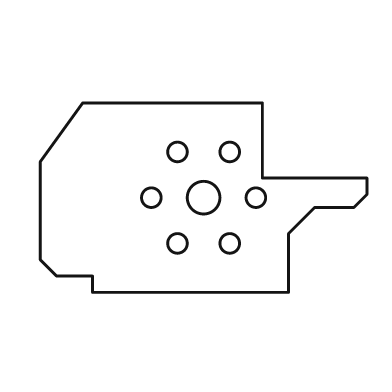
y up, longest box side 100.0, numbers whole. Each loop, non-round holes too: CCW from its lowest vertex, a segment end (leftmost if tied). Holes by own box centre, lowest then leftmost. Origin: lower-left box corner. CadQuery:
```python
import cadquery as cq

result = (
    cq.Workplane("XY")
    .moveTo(16.0, 0.0)
    .lineTo(76.0, 0.0)
    .lineTo(76.0, 18.0)
    .lineTo(84.0, 26.0)
    .lineTo(96.0, 26.0)
    .lineTo(100.0, 30.0)
    .lineTo(100.0, 35.0)
    .lineTo(68.0, 35.0)
    .lineTo(68.0, 58.0)
    .lineTo(13.0, 58.0)
    .lineTo(0.0, 40.0)
    .lineTo(0.0, 10.0)
    .lineTo(5.0, 5.0)
    .lineTo(16.0, 5.0)
    .close()
    .moveTo(42.0, 15.0)
    .circle(3.0)
    .moveTo(58.0, 15.0)
    .circle(3.0)
    .moveTo(34.0, 29.0)
    .circle(3.0)
    .moveTo(50.0, 29.0)
    .circle(5.0)
    .moveTo(66.0, 29.0)
    .circle(3.0)
    .moveTo(42.0, 43.0)
    .circle(3.0)
    .moveTo(58.0, 43.0)
    .circle(3.0)
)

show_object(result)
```